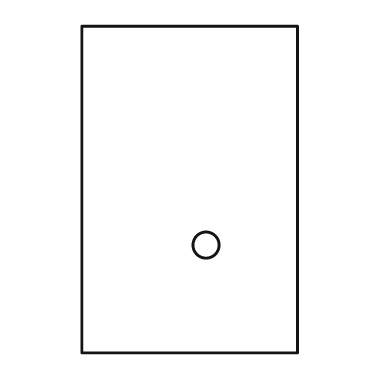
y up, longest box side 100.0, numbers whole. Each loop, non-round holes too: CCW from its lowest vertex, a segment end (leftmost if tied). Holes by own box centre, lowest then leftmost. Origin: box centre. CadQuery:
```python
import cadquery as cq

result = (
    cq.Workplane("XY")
    .moveTo(-33.0, -50.0)
    .lineTo(33.0, -50.0)
    .lineTo(33.0, 50.0)
    .lineTo(-33.0, 50.0)
    .close()
    .moveTo(5.0, -17.0)
    .circle(4.0)
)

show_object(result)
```